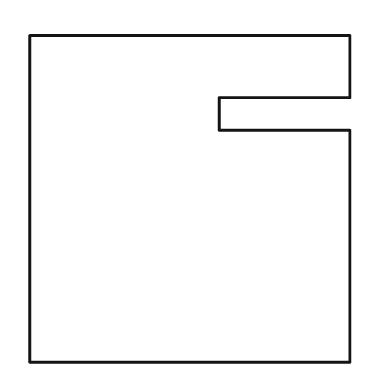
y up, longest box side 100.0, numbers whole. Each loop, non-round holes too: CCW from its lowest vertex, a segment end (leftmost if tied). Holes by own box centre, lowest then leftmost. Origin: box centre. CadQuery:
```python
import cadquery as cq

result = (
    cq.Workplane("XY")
    .moveTo(-49.0, -50.0)
    .lineTo(49.0, -50.0)
    .lineTo(49.0, 21.0)
    .lineTo(9.0, 21.0)
    .lineTo(9.0, 31.0)
    .lineTo(49.0, 31.0)
    .lineTo(49.0, 50.0)
    .lineTo(-49.0, 50.0)
    .close()
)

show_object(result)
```